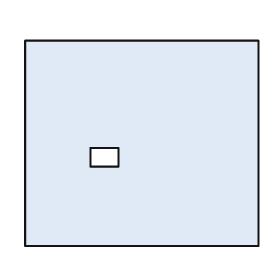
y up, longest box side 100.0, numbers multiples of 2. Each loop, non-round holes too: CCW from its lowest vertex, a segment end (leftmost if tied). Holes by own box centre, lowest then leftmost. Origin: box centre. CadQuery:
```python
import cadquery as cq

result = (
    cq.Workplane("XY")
    .moveTo(-50.0, -44.0)
    .lineTo(50.0, -44.0)
    .lineTo(50.0, 44.0)
    .lineTo(-50.0, 44.0)
    .close()
    .moveTo(-22.0, -10.0)
    .lineTo(-10.0, -10.0)
    .lineTo(-10.0, -2.0)
    .lineTo(-22.0, -2.0)
    .close()
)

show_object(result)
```